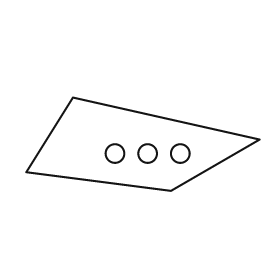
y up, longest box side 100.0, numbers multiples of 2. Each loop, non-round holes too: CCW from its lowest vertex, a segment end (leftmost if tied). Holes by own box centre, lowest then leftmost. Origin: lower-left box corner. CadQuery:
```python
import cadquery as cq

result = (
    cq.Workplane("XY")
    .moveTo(62.0, 0.0)
    .lineTo(100.0, 22.0)
    .lineTo(20.0, 40.0)
    .lineTo(0.0, 8.0)
    .close()
    .moveTo(38.0, 16.0)
    .circle(4.0)
    .moveTo(52.0, 16.0)
    .circle(4.0)
    .moveTo(66.0, 16.0)
    .circle(4.0)
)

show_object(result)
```